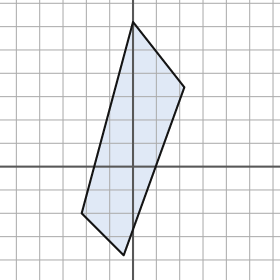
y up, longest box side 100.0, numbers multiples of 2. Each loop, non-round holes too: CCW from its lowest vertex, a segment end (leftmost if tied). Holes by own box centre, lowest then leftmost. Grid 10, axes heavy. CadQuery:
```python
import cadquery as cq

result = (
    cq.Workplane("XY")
    .moveTo(-4.0, -38.0)
    .lineTo(22.0, 34.0)
    .lineTo(0.0, 62.0)
    .lineTo(-22.0, -20.0)
    .close()
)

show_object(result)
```